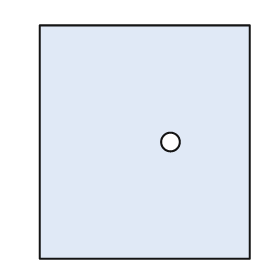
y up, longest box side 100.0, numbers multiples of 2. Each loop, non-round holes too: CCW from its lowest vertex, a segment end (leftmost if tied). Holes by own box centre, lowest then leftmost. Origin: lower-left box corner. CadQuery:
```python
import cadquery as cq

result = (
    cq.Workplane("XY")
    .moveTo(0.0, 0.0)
    .lineTo(90.0, 0.0)
    .lineTo(90.0, 100.0)
    .lineTo(0.0, 100.0)
    .close()
    .moveTo(56.0, 50.0)
    .circle(4.0)
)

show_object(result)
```